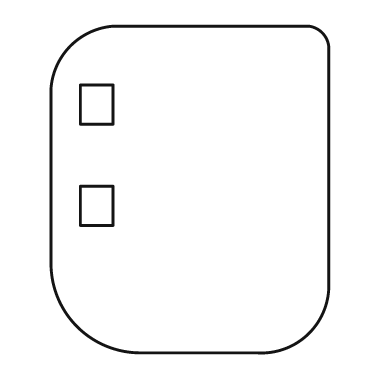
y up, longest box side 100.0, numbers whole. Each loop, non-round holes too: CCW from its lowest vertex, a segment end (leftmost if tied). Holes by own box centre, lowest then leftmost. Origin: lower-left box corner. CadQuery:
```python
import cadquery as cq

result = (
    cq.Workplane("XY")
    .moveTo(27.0, 0.0)
    .lineTo(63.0, 0.0)
    .threePointArc((79.0, 6.0), (85.0, 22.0))
    .lineTo(85.0, 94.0)
    .threePointArc((83.0, 98.0), (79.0, 100.0))
    .lineTo(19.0, 100.0)
    .threePointArc((6.0, 94.0), (0.0, 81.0))
    .lineTo(0.0, 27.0)
    .threePointArc((8.0, 8.0), (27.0, 0.0))
    .close()
    .moveTo(9.0, 39.0)
    .lineTo(19.0, 39.0)
    .lineTo(19.0, 51.0)
    .lineTo(9.0, 51.0)
    .close()
    .moveTo(9.0, 70.0)
    .lineTo(19.0, 70.0)
    .lineTo(19.0, 82.0)
    .lineTo(9.0, 82.0)
    .close()
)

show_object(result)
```